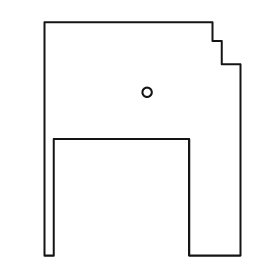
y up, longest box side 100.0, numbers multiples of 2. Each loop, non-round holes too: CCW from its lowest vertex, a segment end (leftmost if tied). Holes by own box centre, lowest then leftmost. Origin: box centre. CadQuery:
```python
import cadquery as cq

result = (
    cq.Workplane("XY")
    .moveTo(-42.0, -50.0)
    .lineTo(-38.0, -50.0)
    .lineTo(-38.0, 0.0)
    .lineTo(20.0, 0.0)
    .lineTo(20.0, -50.0)
    .lineTo(42.0, -50.0)
    .lineTo(42.0, 32.0)
    .lineTo(34.0, 32.0)
    .lineTo(34.0, 42.0)
    .lineTo(30.0, 42.0)
    .lineTo(30.0, 50.0)
    .lineTo(-42.0, 50.0)
    .close()
    .moveTo(2.0, 20.0)
    .circle(2.0)
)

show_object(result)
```